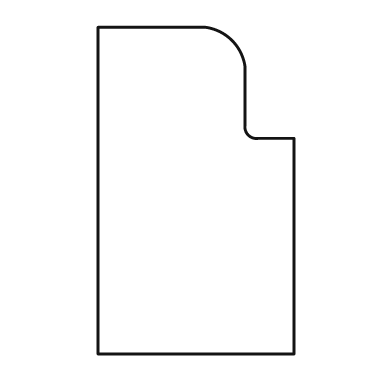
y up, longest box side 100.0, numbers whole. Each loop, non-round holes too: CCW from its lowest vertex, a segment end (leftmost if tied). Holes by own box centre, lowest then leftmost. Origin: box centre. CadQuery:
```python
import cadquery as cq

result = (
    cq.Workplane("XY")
    .moveTo(-30.0, -50.0)
    .lineTo(30.0, -50.0)
    .lineTo(30.0, 16.0)
    .lineTo(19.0, 16.0)
    .threePointArc((16.0, 17.0), (15.0, 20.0))
    .lineTo(15.0, 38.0)
    .threePointArc((11.0, 46.0), (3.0, 50.0))
    .lineTo(-30.0, 50.0)
    .close()
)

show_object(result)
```